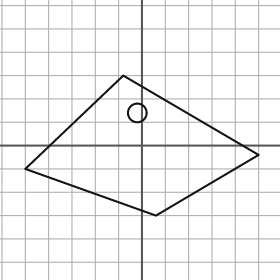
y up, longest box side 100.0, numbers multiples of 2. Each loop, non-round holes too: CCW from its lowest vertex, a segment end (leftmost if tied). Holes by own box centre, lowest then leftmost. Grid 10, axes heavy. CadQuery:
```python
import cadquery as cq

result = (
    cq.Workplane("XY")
    .moveTo(6.0, -30.0)
    .lineTo(50.0, -4.0)
    .lineTo(-8.0, 30.0)
    .lineTo(-50.0, -10.0)
    .close()
    .moveTo(-2.0, 14.0)
    .circle(4.0)
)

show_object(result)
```